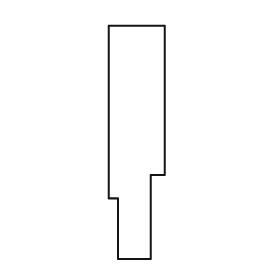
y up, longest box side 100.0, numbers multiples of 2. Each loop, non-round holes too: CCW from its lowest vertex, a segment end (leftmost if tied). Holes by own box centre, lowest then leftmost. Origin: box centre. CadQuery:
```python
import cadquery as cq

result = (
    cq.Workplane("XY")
    .moveTo(-8.0, -50.0)
    .lineTo(6.0, -50.0)
    .lineTo(6.0, -14.0)
    .lineTo(12.0, -14.0)
    .lineTo(12.0, 50.0)
    .lineTo(-12.0, 50.0)
    .lineTo(-12.0, -24.0)
    .lineTo(-8.0, -24.0)
    .close()
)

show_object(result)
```